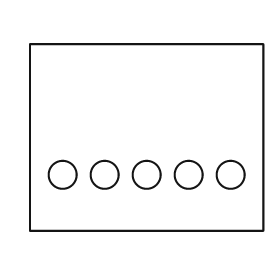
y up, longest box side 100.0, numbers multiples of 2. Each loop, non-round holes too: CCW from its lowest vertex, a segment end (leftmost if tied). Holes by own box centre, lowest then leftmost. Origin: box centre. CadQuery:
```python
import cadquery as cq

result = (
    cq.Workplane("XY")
    .moveTo(-50.0, -40.0)
    .lineTo(50.0, -40.0)
    .lineTo(50.0, 40.0)
    .lineTo(-50.0, 40.0)
    .close()
    .moveTo(-36.0, -16.0)
    .circle(6.0)
    .moveTo(-18.0, -16.0)
    .circle(6.0)
    .moveTo(0.0, -16.0)
    .circle(6.0)
    .moveTo(18.0, -16.0)
    .circle(6.0)
    .moveTo(36.0, -16.0)
    .circle(6.0)
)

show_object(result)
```